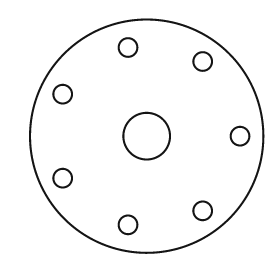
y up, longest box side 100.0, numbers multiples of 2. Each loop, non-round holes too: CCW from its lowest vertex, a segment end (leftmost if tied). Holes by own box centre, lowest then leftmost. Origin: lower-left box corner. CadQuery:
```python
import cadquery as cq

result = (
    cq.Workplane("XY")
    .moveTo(50.0, 50.0)
    .circle(50.0)
    .moveTo(42.0, 12.0)
    .circle(4.0)
    .moveTo(74.0, 18.0)
    .circle(4.0)
    .moveTo(14.0, 32.0)
    .circle(4.0)
    .moveTo(50.0, 50.0)
    .circle(10.0)
    .moveTo(90.0, 50.0)
    .circle(4.0)
    .moveTo(14.0, 68.0)
    .circle(4.0)
    .moveTo(74.0, 82.0)
    .circle(4.0)
    .moveTo(42.0, 88.0)
    .circle(4.0)
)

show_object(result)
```